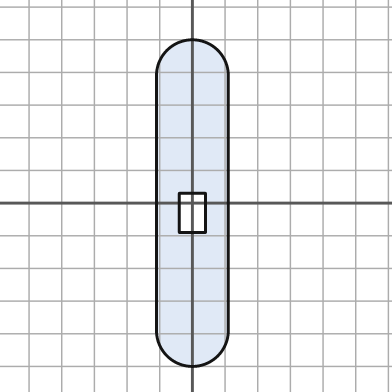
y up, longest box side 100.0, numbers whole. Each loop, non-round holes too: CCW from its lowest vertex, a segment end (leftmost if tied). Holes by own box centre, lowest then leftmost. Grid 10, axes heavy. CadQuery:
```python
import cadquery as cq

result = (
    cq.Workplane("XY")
    .moveTo(-11.0, -39.0)
    .threePointArc((0.0, -50.0), (11.0, -39.0))
    .lineTo(11.0, 39.0)
    .threePointArc((0.0, 50.0), (-11.0, 39.0))
    .close()
    .moveTo(-4.0, -9.0)
    .lineTo(4.0, -9.0)
    .lineTo(4.0, 3.0)
    .lineTo(-4.0, 3.0)
    .close()
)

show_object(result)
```